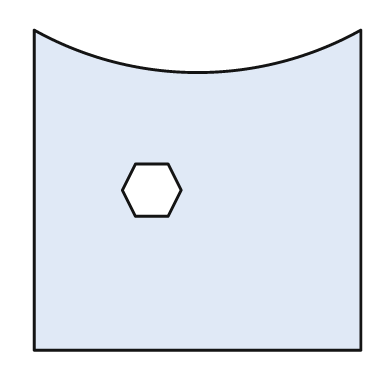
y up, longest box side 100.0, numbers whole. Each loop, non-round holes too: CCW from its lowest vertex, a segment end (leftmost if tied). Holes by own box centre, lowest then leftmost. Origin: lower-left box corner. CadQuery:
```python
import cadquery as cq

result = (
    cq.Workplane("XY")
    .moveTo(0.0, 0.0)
    .lineTo(100.0, 0.0)
    .lineTo(100.0, 98.0)
    .threePointArc((50.0, 85.0), (0.0, 98.0))
    .close()
    .moveTo(31.0, 41.0)
    .lineTo(41.0, 41.0)
    .lineTo(45.0, 49.0)
    .lineTo(41.0, 57.0)
    .lineTo(31.0, 57.0)
    .lineTo(27.0, 49.0)
    .close()
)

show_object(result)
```